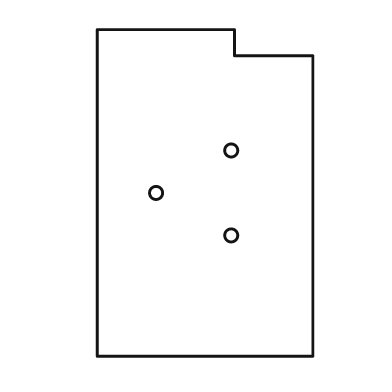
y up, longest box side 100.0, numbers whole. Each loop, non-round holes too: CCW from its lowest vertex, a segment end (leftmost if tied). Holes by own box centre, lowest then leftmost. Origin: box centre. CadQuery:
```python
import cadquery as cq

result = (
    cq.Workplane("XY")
    .moveTo(-33.0, -50.0)
    .lineTo(33.0, -50.0)
    .lineTo(33.0, 42.0)
    .lineTo(9.0, 42.0)
    .lineTo(9.0, 50.0)
    .lineTo(-33.0, 50.0)
    .close()
    .moveTo(8.0, -13.0)
    .circle(2.0)
    .moveTo(-15.0, 0.0)
    .circle(2.0)
    .moveTo(8.0, 13.0)
    .circle(2.0)
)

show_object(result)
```